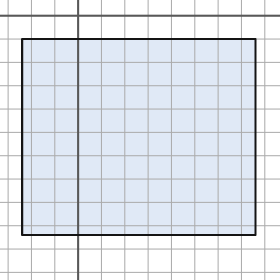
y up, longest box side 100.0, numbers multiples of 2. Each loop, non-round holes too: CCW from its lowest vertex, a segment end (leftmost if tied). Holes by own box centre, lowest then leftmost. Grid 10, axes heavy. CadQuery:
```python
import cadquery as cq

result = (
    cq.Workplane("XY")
    .moveTo(-24.0, -94.0)
    .lineTo(76.0, -94.0)
    .lineTo(76.0, -10.0)
    .lineTo(-24.0, -10.0)
    .close()
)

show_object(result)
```